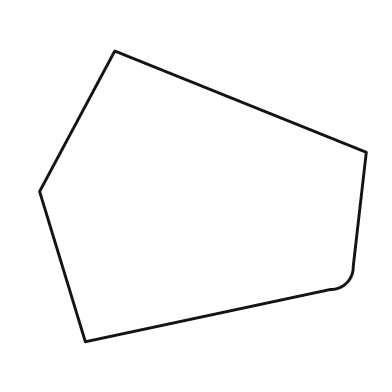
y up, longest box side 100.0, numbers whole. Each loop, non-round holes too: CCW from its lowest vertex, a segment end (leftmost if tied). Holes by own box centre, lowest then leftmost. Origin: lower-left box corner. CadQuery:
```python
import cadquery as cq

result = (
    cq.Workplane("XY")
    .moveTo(14.0, 0.0)
    .lineTo(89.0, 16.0)
    .threePointArc((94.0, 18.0), (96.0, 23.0))
    .lineTo(100.0, 58.0)
    .lineTo(23.0, 89.0)
    .lineTo(0.0, 46.0)
    .close()
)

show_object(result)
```